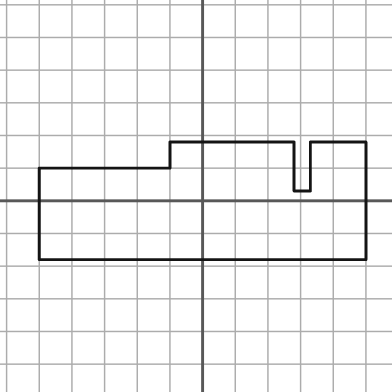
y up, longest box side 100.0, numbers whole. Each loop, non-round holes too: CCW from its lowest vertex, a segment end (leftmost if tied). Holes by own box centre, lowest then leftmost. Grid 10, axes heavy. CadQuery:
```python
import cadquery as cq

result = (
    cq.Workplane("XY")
    .moveTo(-50.0, -18.0)
    .lineTo(50.0, -18.0)
    .lineTo(50.0, 18.0)
    .lineTo(33.0, 18.0)
    .lineTo(33.0, 3.0)
    .lineTo(28.0, 3.0)
    .lineTo(28.0, 18.0)
    .lineTo(-10.0, 18.0)
    .lineTo(-10.0, 10.0)
    .lineTo(-50.0, 10.0)
    .close()
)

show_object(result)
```